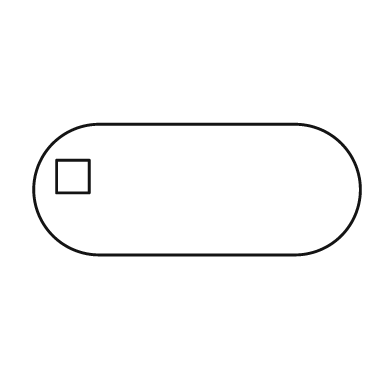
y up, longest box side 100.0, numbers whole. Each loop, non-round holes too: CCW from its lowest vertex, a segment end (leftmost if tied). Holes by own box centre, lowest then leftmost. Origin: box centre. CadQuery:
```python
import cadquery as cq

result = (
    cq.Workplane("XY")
    .moveTo(-30.0, -20.0)
    .lineTo(30.0, -20.0)
    .threePointArc((50.0, 0.0), (30.0, 20.0))
    .lineTo(-30.0, 20.0)
    .threePointArc((-50.0, 0.0), (-30.0, -20.0))
    .close()
    .moveTo(-43.0, -1.0)
    .lineTo(-33.0, -1.0)
    .lineTo(-33.0, 9.0)
    .lineTo(-43.0, 9.0)
    .close()
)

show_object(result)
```